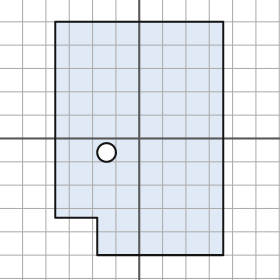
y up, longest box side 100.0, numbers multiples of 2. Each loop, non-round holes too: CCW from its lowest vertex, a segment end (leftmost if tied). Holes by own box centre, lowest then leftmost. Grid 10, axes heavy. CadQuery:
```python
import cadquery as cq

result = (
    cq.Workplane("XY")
    .moveTo(-18.0, -50.0)
    .lineTo(36.0, -50.0)
    .lineTo(36.0, 50.0)
    .lineTo(-36.0, 50.0)
    .lineTo(-36.0, -34.0)
    .lineTo(-18.0, -34.0)
    .close()
    .moveTo(-14.0, -6.0)
    .circle(4.0)
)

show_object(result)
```